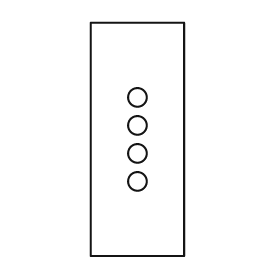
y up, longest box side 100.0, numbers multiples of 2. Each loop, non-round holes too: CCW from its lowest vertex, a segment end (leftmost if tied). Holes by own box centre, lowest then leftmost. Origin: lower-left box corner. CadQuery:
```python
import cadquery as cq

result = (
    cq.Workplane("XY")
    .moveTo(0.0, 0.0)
    .lineTo(40.0, 0.0)
    .lineTo(40.0, 100.0)
    .lineTo(0.0, 100.0)
    .close()
    .moveTo(20.0, 32.0)
    .circle(4.0)
    .moveTo(20.0, 44.0)
    .circle(4.0)
    .moveTo(20.0, 56.0)
    .circle(4.0)
    .moveTo(20.0, 68.0)
    .circle(4.0)
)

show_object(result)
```